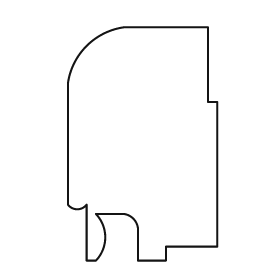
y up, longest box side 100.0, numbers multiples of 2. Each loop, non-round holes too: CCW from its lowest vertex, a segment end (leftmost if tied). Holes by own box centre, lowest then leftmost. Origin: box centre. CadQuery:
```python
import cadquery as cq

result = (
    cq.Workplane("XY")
    .moveTo(-24.0, -50.0)
    .lineTo(-20.0, -50.0)
    .threePointArc((-16.0, -40.0), (-20.0, -30.0))
    .lineTo(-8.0, -30.0)
    .threePointArc((-4.0, -32.0), (-2.0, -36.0))
    .lineTo(-2.0, -50.0)
    .lineTo(10.0, -50.0)
    .lineTo(10.0, -44.0)
    .lineTo(32.0, -44.0)
    .lineTo(32.0, 18.0)
    .lineTo(28.0, 18.0)
    .lineTo(28.0, 50.0)
    .lineTo(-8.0, 50.0)
    .threePointArc((-24.0, 42.0), (-32.0, 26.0))
    .lineTo(-32.0, -26.0)
    .threePointArc((-28.0, -28.0), (-24.0, -26.0))
    .close()
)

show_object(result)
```